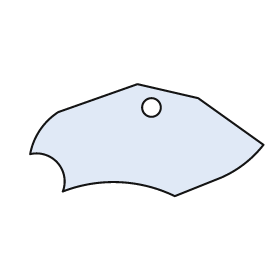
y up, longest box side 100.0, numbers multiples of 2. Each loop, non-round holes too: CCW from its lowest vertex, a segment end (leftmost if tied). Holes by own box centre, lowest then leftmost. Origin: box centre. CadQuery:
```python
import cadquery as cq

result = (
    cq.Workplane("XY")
    .moveTo(12.0, -24.0)
    .lineTo(32.0, -16.0)
    .threePointArc((42.0, -10.0), (50.0, -2.0))
    .lineTo(22.0, 18.0)
    .lineTo(-4.0, 24.0)
    .lineTo(-38.0, 12.0)
    .threePointArc((-46.0, 4.0), (-50.0, -6.0))
    .threePointArc((-38.0, -10.0), (-36.0, -22.0))
    .threePointArc((-12.0, -18.0), (12.0, -24.0))
    .close()
    .moveTo(2.0, 14.0)
    .circle(4.0)
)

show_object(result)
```